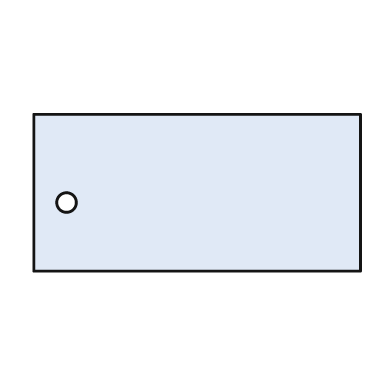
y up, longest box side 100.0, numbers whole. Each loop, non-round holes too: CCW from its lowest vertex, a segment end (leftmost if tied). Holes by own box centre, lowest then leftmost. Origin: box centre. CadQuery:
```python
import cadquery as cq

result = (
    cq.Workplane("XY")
    .moveTo(-50.0, -24.0)
    .lineTo(50.0, -24.0)
    .lineTo(50.0, 24.0)
    .lineTo(-50.0, 24.0)
    .close()
    .moveTo(-40.0, -3.0)
    .circle(3.0)
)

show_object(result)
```